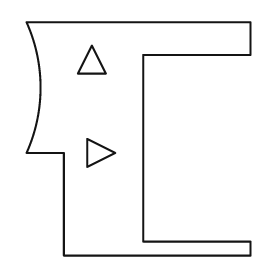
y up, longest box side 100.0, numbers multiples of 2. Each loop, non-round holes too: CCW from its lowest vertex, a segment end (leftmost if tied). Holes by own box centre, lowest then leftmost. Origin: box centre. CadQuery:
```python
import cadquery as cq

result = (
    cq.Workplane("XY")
    .moveTo(-32.0, -50.0)
    .lineTo(48.0, -50.0)
    .lineTo(48.0, -44.0)
    .lineTo(2.0, -44.0)
    .lineTo(2.0, 36.0)
    .lineTo(48.0, 36.0)
    .lineTo(48.0, 50.0)
    .lineTo(-48.0, 50.0)
    .threePointArc((-42.0, 22.0), (-48.0, -6.0))
    .lineTo(-32.0, -6.0)
    .close()
    .moveTo(-22.0, -12.0)
    .lineTo(-10.0, -6.0)
    .lineTo(-22.0, 0.0)
    .close()
    .moveTo(-26.0, 28.0)
    .lineTo(-14.0, 28.0)
    .lineTo(-20.0, 40.0)
    .close()
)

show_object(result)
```